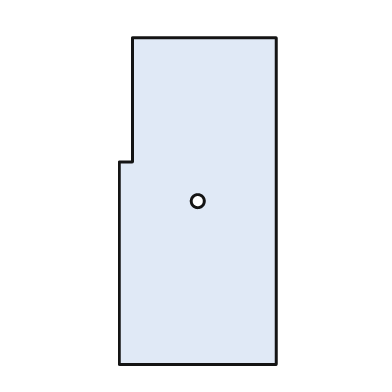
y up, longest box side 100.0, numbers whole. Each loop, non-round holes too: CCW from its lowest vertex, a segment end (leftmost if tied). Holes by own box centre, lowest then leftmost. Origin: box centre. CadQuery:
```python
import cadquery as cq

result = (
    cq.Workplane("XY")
    .moveTo(-24.0, -50.0)
    .lineTo(24.0, -50.0)
    .lineTo(24.0, 50.0)
    .lineTo(-20.0, 50.0)
    .lineTo(-20.0, 12.0)
    .lineTo(-24.0, 12.0)
    .close()
    .moveTo(0.0, 0.0)
    .circle(2.0)
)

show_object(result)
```